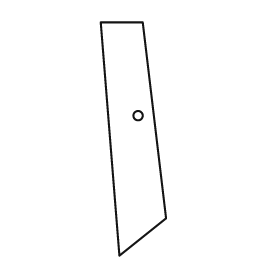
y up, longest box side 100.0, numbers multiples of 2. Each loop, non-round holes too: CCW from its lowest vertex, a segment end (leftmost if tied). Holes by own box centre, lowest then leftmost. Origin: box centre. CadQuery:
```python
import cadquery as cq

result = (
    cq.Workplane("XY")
    .moveTo(-6.0, -50.0)
    .lineTo(14.0, -34.0)
    .lineTo(4.0, 50.0)
    .lineTo(-14.0, 50.0)
    .close()
    .moveTo(2.0, 10.0)
    .circle(2.0)
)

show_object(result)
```